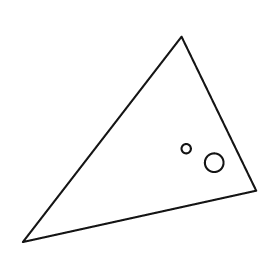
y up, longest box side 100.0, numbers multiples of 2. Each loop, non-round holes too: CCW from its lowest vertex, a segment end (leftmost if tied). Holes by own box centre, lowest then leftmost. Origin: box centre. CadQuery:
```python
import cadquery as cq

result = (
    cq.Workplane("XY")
    .moveTo(-50.0, -44.0)
    .lineTo(50.0, -22.0)
    .lineTo(18.0, 44.0)
    .close()
    .moveTo(32.0, -10.0)
    .circle(4.0)
    .moveTo(20.0, -4.0)
    .circle(2.0)
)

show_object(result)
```